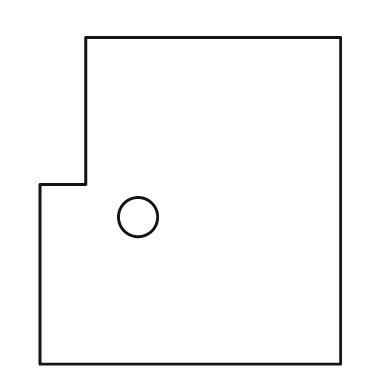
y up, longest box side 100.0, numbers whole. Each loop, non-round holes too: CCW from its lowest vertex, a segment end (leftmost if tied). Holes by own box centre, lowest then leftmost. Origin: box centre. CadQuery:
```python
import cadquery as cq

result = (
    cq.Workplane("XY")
    .moveTo(-46.0, -50.0)
    .lineTo(46.0, -50.0)
    .lineTo(46.0, 50.0)
    .lineTo(-32.0, 50.0)
    .lineTo(-32.0, 5.0)
    .lineTo(-46.0, 5.0)
    .close()
    .moveTo(-16.0, -5.0)
    .circle(6.0)
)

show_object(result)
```